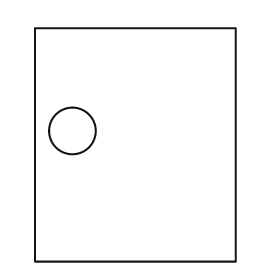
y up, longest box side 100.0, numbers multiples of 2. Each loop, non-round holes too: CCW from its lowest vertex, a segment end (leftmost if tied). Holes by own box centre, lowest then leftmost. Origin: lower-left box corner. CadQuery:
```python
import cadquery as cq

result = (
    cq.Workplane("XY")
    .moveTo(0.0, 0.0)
    .lineTo(86.0, 0.0)
    .lineTo(86.0, 100.0)
    .lineTo(0.0, 100.0)
    .close()
    .moveTo(16.0, 56.0)
    .circle(10.0)
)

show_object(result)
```